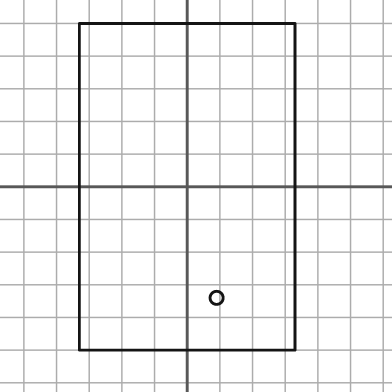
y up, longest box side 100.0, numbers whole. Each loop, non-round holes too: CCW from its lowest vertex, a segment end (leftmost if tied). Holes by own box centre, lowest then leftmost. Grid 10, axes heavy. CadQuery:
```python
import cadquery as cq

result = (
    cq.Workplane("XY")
    .moveTo(-33.0, -50.0)
    .lineTo(33.0, -50.0)
    .lineTo(33.0, 50.0)
    .lineTo(-33.0, 50.0)
    .close()
    .moveTo(9.0, -34.0)
    .circle(2.0)
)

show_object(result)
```